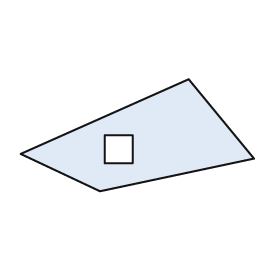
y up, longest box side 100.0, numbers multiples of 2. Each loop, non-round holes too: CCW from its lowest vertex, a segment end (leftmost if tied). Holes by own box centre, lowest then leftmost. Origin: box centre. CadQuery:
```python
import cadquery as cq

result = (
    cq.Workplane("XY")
    .moveTo(-16.0, -24.0)
    .lineTo(50.0, -10.0)
    .lineTo(22.0, 24.0)
    .lineTo(-50.0, -8.0)
    .close()
    .moveTo(-14.0, -12.0)
    .lineTo(-2.0, -12.0)
    .lineTo(-2.0, 0.0)
    .lineTo(-14.0, 0.0)
    .close()
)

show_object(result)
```